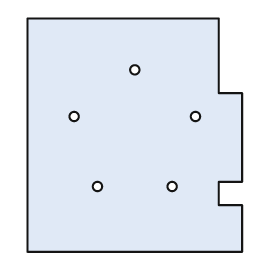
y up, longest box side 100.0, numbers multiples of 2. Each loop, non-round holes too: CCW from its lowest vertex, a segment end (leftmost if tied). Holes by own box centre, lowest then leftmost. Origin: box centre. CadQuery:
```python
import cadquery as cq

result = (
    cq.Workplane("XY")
    .moveTo(-46.0, -50.0)
    .lineTo(46.0, -50.0)
    .lineTo(46.0, -30.0)
    .lineTo(36.0, -30.0)
    .lineTo(36.0, -20.0)
    .lineTo(46.0, -20.0)
    .lineTo(46.0, 18.0)
    .lineTo(36.0, 18.0)
    .lineTo(36.0, 50.0)
    .lineTo(-46.0, 50.0)
    .close()
    .moveTo(-16.0, -22.0)
    .circle(2.0)
    .moveTo(16.0, -22.0)
    .circle(2.0)
    .moveTo(-26.0, 8.0)
    .circle(2.0)
    .moveTo(26.0, 8.0)
    .circle(2.0)
    .moveTo(0.0, 28.0)
    .circle(2.0)
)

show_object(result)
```